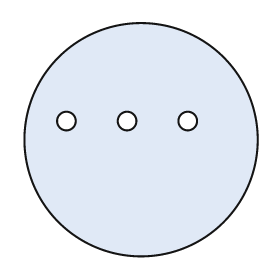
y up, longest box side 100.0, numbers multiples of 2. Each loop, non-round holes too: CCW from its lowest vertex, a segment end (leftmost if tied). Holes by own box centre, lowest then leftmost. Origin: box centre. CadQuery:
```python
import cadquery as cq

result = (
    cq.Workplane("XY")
    .moveTo(0.0, 0.0)
    .circle(50.0)
    .moveTo(-32.0, 8.0)
    .circle(4.0)
    .moveTo(-6.0, 8.0)
    .circle(4.0)
    .moveTo(20.0, 8.0)
    .circle(4.0)
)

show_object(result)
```